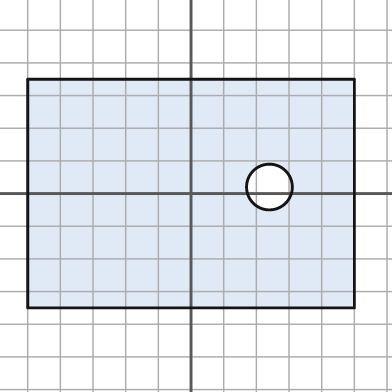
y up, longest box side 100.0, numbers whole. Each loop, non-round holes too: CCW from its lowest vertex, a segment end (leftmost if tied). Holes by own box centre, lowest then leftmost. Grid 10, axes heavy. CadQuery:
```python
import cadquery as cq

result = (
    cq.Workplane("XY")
    .moveTo(-50.0, -35.0)
    .lineTo(50.0, -35.0)
    .lineTo(50.0, 35.0)
    .lineTo(-50.0, 35.0)
    .close()
    .moveTo(24.0, 2.0)
    .circle(7.0)
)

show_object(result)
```